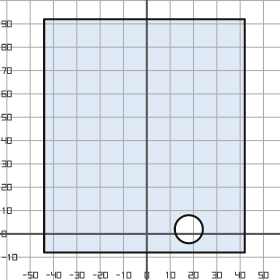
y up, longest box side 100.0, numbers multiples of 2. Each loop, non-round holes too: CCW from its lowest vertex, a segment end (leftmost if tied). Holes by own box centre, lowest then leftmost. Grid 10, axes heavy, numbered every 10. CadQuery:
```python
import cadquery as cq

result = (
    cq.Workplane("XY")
    .moveTo(-44.0, -8.0)
    .lineTo(42.0, -8.0)
    .lineTo(42.0, 92.0)
    .lineTo(-44.0, 92.0)
    .close()
    .moveTo(18.0, 2.0)
    .circle(6.0)
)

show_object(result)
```